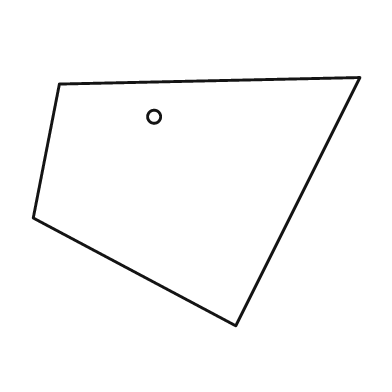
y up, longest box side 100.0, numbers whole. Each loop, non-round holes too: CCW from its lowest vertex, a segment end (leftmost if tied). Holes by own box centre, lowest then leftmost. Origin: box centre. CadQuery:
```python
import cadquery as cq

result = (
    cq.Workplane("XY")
    .moveTo(12.0, -38.0)
    .lineTo(50.0, 38.0)
    .lineTo(-42.0, 36.0)
    .lineTo(-50.0, -5.0)
    .close()
    .moveTo(-13.0, 26.0)
    .circle(2.0)
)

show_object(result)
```